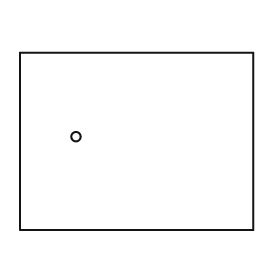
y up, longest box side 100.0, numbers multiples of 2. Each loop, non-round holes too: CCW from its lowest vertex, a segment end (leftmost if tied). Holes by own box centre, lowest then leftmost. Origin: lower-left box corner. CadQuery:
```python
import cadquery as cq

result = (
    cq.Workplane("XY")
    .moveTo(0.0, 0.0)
    .lineTo(100.0, 0.0)
    .lineTo(100.0, 76.0)
    .lineTo(0.0, 76.0)
    .close()
    .moveTo(24.0, 40.0)
    .circle(2.0)
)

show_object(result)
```